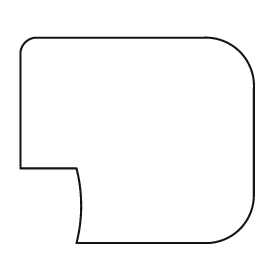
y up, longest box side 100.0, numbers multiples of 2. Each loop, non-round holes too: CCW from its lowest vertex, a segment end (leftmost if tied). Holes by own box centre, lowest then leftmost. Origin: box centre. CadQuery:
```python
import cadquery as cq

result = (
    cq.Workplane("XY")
    .moveTo(-26.0, -44.0)
    .lineTo(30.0, -44.0)
    .threePointArc((44.0, -38.0), (50.0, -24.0))
    .lineTo(50.0, 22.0)
    .threePointArc((44.0, 38.0), (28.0, 44.0))
    .lineTo(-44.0, 44.0)
    .threePointArc((-48.0, 42.0), (-50.0, 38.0))
    .lineTo(-50.0, -12.0)
    .lineTo(-26.0, -12.0)
    .threePointArc((-24.0, -28.0), (-26.0, -44.0))
    .close()
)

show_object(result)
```